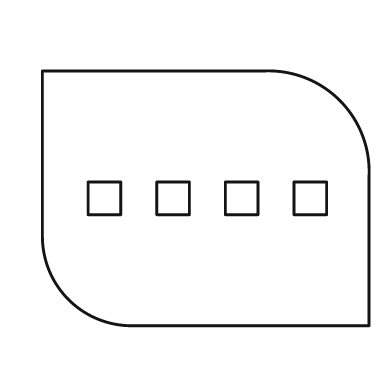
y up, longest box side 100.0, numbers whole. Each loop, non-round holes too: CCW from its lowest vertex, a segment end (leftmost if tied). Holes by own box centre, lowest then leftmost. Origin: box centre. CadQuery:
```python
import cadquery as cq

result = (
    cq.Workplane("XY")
    .moveTo(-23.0, -39.0)
    .lineTo(50.0, -39.0)
    .lineTo(50.0, 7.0)
    .threePointArc((41.0, 30.0), (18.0, 39.0))
    .lineTo(-50.0, 39.0)
    .lineTo(-50.0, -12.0)
    .threePointArc((-42.0, -31.0), (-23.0, -39.0))
    .close()
    .moveTo(-36.0, -5.0)
    .lineTo(-26.0, -5.0)
    .lineTo(-26.0, 5.0)
    .lineTo(-36.0, 5.0)
    .close()
    .moveTo(-15.0, -5.0)
    .lineTo(-5.0, -5.0)
    .lineTo(-5.0, 5.0)
    .lineTo(-15.0, 5.0)
    .close()
    .moveTo(6.0, -5.0)
    .lineTo(16.0, -5.0)
    .lineTo(16.0, 5.0)
    .lineTo(6.0, 5.0)
    .close()
    .moveTo(27.0, -5.0)
    .lineTo(37.0, -5.0)
    .lineTo(37.0, 5.0)
    .lineTo(27.0, 5.0)
    .close()
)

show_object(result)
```